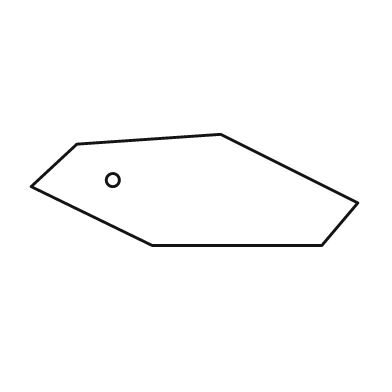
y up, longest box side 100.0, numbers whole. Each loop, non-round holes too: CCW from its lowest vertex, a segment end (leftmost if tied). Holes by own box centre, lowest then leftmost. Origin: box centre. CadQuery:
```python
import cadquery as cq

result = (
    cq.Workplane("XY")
    .moveTo(-13.0, -17.0)
    .lineTo(39.0, -17.0)
    .lineTo(50.0, -4.0)
    .lineTo(8.0, 17.0)
    .lineTo(-36.0, 14.0)
    .lineTo(-50.0, 1.0)
    .close()
    .moveTo(-25.0, 3.0)
    .circle(2.0)
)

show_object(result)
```